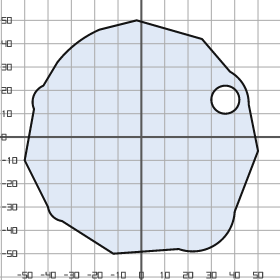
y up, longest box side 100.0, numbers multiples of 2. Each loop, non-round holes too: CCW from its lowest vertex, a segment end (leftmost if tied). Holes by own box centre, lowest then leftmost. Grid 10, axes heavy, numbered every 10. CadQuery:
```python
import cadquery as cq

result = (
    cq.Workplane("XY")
    .moveTo(-12.0, -50.0)
    .lineTo(16.0, -48.0)
    .threePointArc((32.0, -46.0), (40.0, -32.0))
    .lineTo(50.0, -6.0)
    .lineTo(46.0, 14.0)
    .threePointArc((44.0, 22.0), (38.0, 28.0))
    .lineTo(26.0, 42.0)
    .lineTo(-2.0, 50.0)
    .lineTo(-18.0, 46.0)
    .threePointArc((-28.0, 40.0), (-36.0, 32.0))
    .lineTo(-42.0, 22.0)
    .threePointArc((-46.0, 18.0), (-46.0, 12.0))
    .lineTo(-50.0, -10.0)
    .lineTo(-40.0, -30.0)
    .threePointArc((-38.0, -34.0), (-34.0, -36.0))
    .close()
    .moveTo(36.0, 16.0)
    .circle(6.0)
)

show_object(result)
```